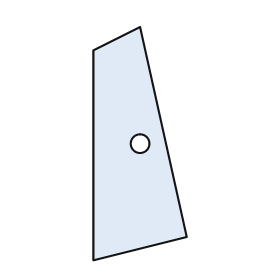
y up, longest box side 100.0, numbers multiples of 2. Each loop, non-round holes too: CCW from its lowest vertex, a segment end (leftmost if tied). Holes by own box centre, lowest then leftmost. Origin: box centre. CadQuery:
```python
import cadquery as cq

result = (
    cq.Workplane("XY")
    .moveTo(-20.0, -50.0)
    .lineTo(20.0, -40.0)
    .lineTo(0.0, 50.0)
    .lineTo(-20.0, 40.0)
    .close()
    .moveTo(0.0, 0.0)
    .circle(4.0)
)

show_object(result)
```